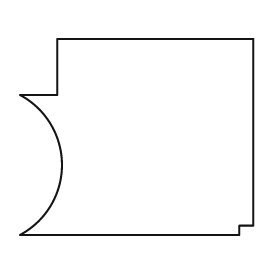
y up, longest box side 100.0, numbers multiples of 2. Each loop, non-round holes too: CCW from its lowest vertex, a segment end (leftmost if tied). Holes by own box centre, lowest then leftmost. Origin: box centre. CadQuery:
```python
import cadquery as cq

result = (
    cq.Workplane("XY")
    .moveTo(-50.0, -42.0)
    .lineTo(44.0, -42.0)
    .lineTo(44.0, -38.0)
    .lineTo(50.0, -38.0)
    .lineTo(50.0, 42.0)
    .lineTo(-34.0, 42.0)
    .lineTo(-34.0, 18.0)
    .lineTo(-50.0, 18.0)
    .threePointArc((-32.0, -12.0), (-50.0, -42.0))
    .close()
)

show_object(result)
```